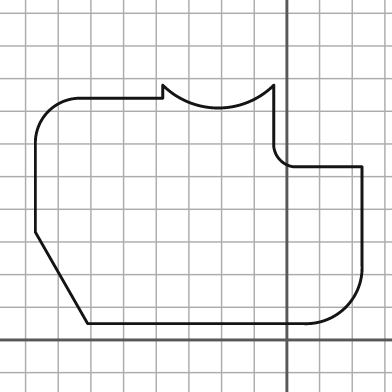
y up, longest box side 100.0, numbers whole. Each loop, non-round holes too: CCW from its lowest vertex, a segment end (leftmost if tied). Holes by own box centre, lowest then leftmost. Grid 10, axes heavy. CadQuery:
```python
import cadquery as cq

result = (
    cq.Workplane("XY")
    .moveTo(-61.0, 5.0)
    .lineTo(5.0, 5.0)
    .threePointArc((18.0, 10.0), (23.0, 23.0))
    .lineTo(23.0, 53.0)
    .lineTo(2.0, 53.0)
    .threePointArc((-2.0, 55.0), (-4.0, 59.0))
    .lineTo(-4.0, 78.0)
    .threePointArc((-21.0, 71.0), (-38.0, 78.0))
    .lineTo(-38.0, 74.0)
    .lineTo(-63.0, 74.0)
    .threePointArc((-73.0, 70.0), (-77.0, 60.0))
    .lineTo(-77.0, 33.0)
    .close()
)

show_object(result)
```